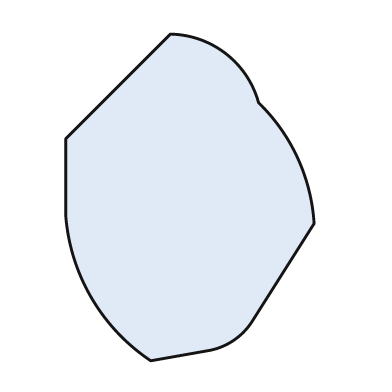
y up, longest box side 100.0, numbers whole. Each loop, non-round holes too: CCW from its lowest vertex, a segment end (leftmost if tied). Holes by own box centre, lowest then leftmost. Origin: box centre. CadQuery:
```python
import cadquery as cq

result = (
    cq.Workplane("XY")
    .moveTo(-12.0, -50.0)
    .lineTo(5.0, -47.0)
    .threePointArc((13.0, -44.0), (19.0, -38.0))
    .lineTo(38.0, -8.0)
    .threePointArc((33.0, 12.0), (21.0, 29.0))
    .threePointArc((11.0, 44.0), (-6.0, 50.0))
    .lineTo(-38.0, 18.0)
    .lineTo(-38.0, -6.0)
    .threePointArc((-30.0, -31.0), (-12.0, -50.0))
    .close()
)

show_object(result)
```